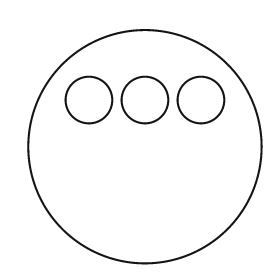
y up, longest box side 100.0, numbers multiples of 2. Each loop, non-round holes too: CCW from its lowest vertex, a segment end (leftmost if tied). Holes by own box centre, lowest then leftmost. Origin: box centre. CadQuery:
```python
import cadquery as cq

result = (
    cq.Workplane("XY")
    .moveTo(0.0, 0.0)
    .circle(50.0)
    .moveTo(-24.0, 20.0)
    .circle(10.0)
    .moveTo(0.0, 20.0)
    .circle(10.0)
    .moveTo(24.0, 20.0)
    .circle(10.0)
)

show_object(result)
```